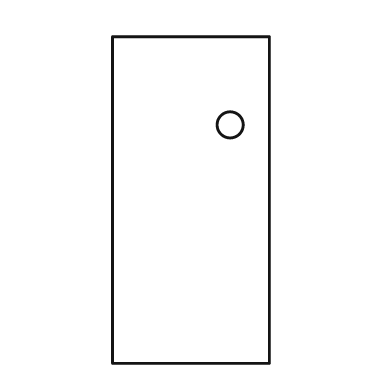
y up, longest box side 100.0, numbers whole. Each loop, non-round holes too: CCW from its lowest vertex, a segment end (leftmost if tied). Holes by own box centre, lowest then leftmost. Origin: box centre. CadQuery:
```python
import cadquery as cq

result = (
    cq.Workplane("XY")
    .moveTo(-24.0, -50.0)
    .lineTo(24.0, -50.0)
    .lineTo(24.0, 50.0)
    .lineTo(-24.0, 50.0)
    .close()
    .moveTo(12.0, 23.0)
    .circle(4.0)
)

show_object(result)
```